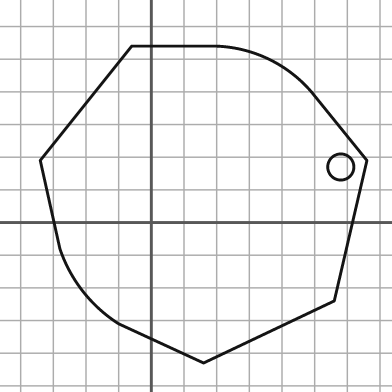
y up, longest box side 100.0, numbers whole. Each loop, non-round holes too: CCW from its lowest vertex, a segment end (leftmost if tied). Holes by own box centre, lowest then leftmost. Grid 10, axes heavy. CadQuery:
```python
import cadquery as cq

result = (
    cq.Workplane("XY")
    .moveTo(16.0, -43.0)
    .lineTo(56.0, -24.0)
    .lineTo(66.0, 19.0)
    .lineTo(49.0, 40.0)
    .threePointArc((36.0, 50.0), (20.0, 54.0))
    .lineTo(-6.0, 54.0)
    .lineTo(-34.0, 19.0)
    .lineTo(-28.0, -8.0)
    .threePointArc((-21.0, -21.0), (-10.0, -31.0))
    .close()
    .moveTo(58.0, 17.0)
    .circle(4.0)
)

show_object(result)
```